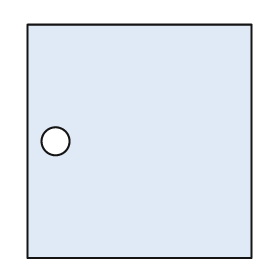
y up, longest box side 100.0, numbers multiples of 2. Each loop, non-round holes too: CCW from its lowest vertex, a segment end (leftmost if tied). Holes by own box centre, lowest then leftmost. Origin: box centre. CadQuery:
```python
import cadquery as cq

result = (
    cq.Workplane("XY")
    .moveTo(-48.0, -50.0)
    .lineTo(48.0, -50.0)
    .lineTo(48.0, 50.0)
    .lineTo(-48.0, 50.0)
    .close()
    .moveTo(-36.0, 0.0)
    .circle(6.0)
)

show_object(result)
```